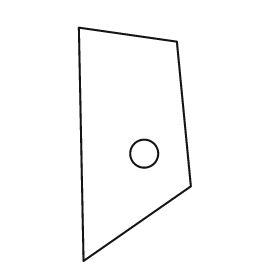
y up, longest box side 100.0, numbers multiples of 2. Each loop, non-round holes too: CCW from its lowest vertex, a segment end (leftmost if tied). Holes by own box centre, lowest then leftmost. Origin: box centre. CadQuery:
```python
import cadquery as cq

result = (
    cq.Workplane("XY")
    .moveTo(-22.0, -50.0)
    .lineTo(24.0, -18.0)
    .lineTo(18.0, 44.0)
    .lineTo(-24.0, 50.0)
    .close()
    .moveTo(4.0, -4.0)
    .circle(6.0)
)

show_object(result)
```